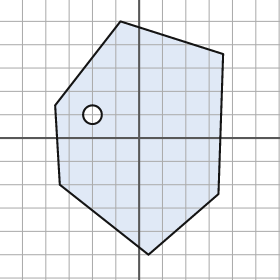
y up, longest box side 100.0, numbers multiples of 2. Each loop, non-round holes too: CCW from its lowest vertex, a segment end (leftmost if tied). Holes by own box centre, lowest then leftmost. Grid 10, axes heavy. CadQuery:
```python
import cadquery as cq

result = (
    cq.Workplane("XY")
    .moveTo(4.0, -50.0)
    .lineTo(34.0, -24.0)
    .lineTo(36.0, 36.0)
    .lineTo(-8.0, 50.0)
    .lineTo(-36.0, 14.0)
    .lineTo(-34.0, -20.0)
    .close()
    .moveTo(-20.0, 10.0)
    .circle(4.0)
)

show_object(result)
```